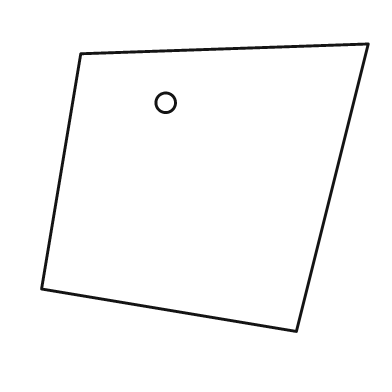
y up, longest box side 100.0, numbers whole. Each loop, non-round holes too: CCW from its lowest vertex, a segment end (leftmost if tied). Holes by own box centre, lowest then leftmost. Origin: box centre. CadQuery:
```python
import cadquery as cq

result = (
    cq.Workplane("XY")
    .moveTo(28.0, -44.0)
    .lineTo(50.0, 44.0)
    .lineTo(-38.0, 41.0)
    .lineTo(-50.0, -31.0)
    .close()
    .moveTo(-12.0, 26.0)
    .circle(3.0)
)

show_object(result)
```